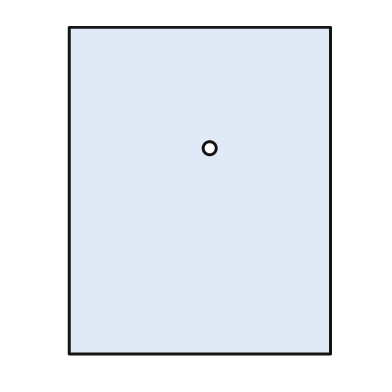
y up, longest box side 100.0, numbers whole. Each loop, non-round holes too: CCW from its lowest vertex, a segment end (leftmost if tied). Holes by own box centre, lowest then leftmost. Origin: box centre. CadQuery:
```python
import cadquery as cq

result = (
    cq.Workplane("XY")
    .moveTo(-40.0, -50.0)
    .lineTo(40.0, -50.0)
    .lineTo(40.0, 50.0)
    .lineTo(-40.0, 50.0)
    .close()
    .moveTo(3.0, 13.0)
    .circle(2.0)
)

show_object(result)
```